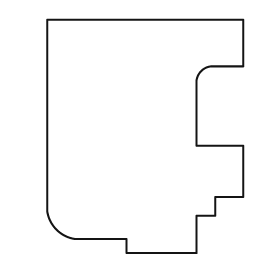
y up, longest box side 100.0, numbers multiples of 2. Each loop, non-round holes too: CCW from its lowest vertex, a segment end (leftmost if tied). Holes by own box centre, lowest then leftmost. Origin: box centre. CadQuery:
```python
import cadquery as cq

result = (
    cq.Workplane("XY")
    .moveTo(-8.0, -50.0)
    .lineTo(22.0, -50.0)
    .lineTo(22.0, -34.0)
    .lineTo(30.0, -34.0)
    .lineTo(30.0, -26.0)
    .lineTo(42.0, -26.0)
    .lineTo(42.0, -4.0)
    .lineTo(22.0, -4.0)
    .lineTo(22.0, 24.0)
    .threePointArc((24.0, 28.0), (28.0, 30.0))
    .lineTo(42.0, 30.0)
    .lineTo(42.0, 50.0)
    .lineTo(-42.0, 50.0)
    .lineTo(-42.0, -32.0)
    .threePointArc((-38.0, -40.0), (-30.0, -44.0))
    .lineTo(-8.0, -44.0)
    .close()
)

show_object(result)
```